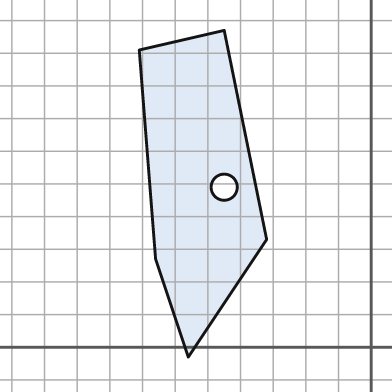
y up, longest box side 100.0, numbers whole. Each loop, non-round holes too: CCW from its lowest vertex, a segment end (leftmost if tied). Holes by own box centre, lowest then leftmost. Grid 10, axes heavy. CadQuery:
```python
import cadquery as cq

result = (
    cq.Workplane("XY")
    .moveTo(-56.0, -3.0)
    .lineTo(-32.0, 33.0)
    .lineTo(-45.0, 97.0)
    .lineTo(-71.0, 91.0)
    .lineTo(-66.0, 27.0)
    .close()
    .moveTo(-45.0, 49.0)
    .circle(4.0)
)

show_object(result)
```